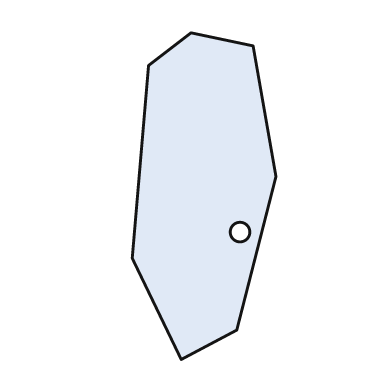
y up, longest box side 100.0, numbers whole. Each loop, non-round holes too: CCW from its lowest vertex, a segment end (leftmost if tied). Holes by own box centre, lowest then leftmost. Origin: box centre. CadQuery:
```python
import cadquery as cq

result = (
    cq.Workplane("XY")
    .moveTo(-7.0, -50.0)
    .lineTo(10.0, -41.0)
    .lineTo(22.0, 6.0)
    .lineTo(15.0, 46.0)
    .lineTo(-4.0, 50.0)
    .lineTo(-17.0, 40.0)
    .lineTo(-22.0, -19.0)
    .close()
    .moveTo(11.0, -11.0)
    .circle(3.0)
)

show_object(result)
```